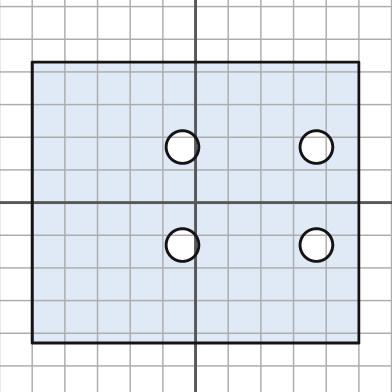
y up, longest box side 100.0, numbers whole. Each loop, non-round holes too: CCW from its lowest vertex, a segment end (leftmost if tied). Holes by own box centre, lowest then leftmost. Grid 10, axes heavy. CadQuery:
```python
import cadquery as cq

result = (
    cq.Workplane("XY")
    .moveTo(-50.0, -43.0)
    .lineTo(50.0, -43.0)
    .lineTo(50.0, 43.0)
    .lineTo(-50.0, 43.0)
    .close()
    .moveTo(-4.0, -13.0)
    .circle(5.0)
    .moveTo(37.0, -13.0)
    .circle(5.0)
    .moveTo(-4.0, 17.0)
    .circle(5.0)
    .moveTo(37.0, 17.0)
    .circle(5.0)
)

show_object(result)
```